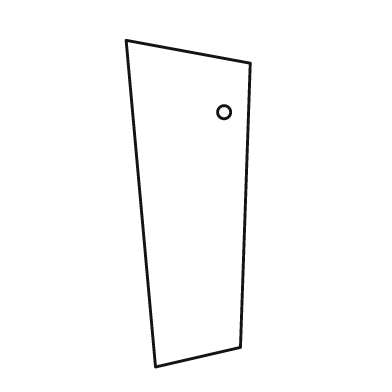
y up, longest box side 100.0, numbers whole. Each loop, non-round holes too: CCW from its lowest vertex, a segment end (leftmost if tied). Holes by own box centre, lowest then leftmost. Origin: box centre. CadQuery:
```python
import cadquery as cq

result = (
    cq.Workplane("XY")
    .moveTo(-10.0, -50.0)
    .lineTo(16.0, -44.0)
    .lineTo(19.0, 43.0)
    .lineTo(-19.0, 50.0)
    .close()
    .moveTo(11.0, 28.0)
    .circle(2.0)
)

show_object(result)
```